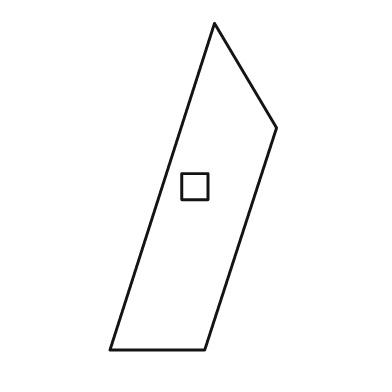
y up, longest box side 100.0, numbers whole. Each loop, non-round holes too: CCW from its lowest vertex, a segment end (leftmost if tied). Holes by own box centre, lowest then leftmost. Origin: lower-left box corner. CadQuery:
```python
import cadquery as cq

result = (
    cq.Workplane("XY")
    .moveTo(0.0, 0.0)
    .lineTo(29.0, 0.0)
    .lineTo(51.0, 68.0)
    .lineTo(32.0, 100.0)
    .close()
    .moveTo(22.0, 46.0)
    .lineTo(30.0, 46.0)
    .lineTo(30.0, 54.0)
    .lineTo(22.0, 54.0)
    .close()
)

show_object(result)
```